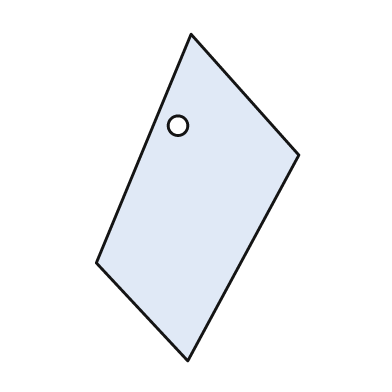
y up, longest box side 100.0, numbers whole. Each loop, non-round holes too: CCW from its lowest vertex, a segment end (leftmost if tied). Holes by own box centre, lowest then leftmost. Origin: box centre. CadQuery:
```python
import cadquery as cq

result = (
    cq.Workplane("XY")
    .moveTo(-3.0, -50.0)
    .lineTo(31.0, 13.0)
    .lineTo(-2.0, 50.0)
    .lineTo(-31.0, -20.0)
    .close()
    .moveTo(-6.0, 22.0)
    .circle(3.0)
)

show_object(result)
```